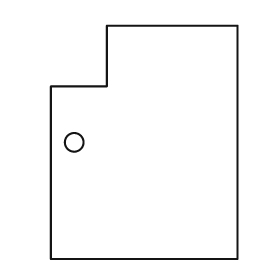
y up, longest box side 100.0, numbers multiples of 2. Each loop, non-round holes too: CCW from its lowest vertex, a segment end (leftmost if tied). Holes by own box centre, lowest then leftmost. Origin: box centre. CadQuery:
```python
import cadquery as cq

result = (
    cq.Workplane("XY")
    .moveTo(-40.0, -50.0)
    .lineTo(40.0, -50.0)
    .lineTo(40.0, 50.0)
    .lineTo(-16.0, 50.0)
    .lineTo(-16.0, 24.0)
    .lineTo(-40.0, 24.0)
    .close()
    .moveTo(-30.0, 0.0)
    .circle(4.0)
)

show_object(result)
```